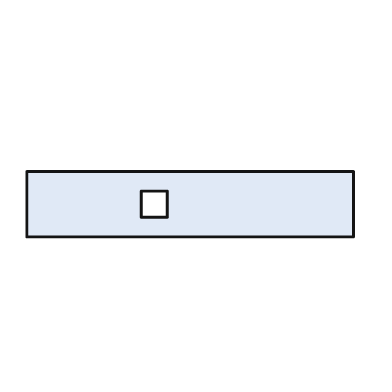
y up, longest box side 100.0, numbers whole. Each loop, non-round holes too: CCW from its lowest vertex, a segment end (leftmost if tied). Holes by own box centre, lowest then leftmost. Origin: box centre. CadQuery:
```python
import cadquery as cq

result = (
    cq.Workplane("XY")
    .moveTo(-50.0, -10.0)
    .lineTo(50.0, -10.0)
    .lineTo(50.0, 10.0)
    .lineTo(-50.0, 10.0)
    .close()
    .moveTo(-15.0, -4.0)
    .lineTo(-7.0, -4.0)
    .lineTo(-7.0, 4.0)
    .lineTo(-15.0, 4.0)
    .close()
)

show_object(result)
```